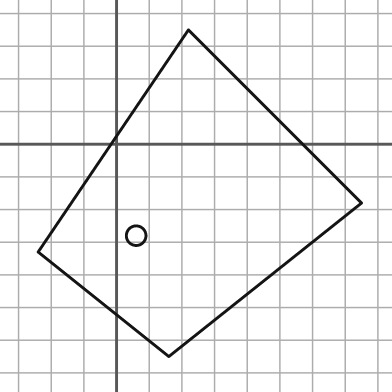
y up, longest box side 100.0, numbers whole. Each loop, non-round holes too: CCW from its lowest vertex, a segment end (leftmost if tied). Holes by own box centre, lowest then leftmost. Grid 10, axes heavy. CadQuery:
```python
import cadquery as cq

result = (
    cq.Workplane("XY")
    .moveTo(16.0, -65.0)
    .lineTo(75.0, -18.0)
    .lineTo(22.0, 35.0)
    .lineTo(-24.0, -33.0)
    .close()
    .moveTo(6.0, -28.0)
    .circle(3.0)
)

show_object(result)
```